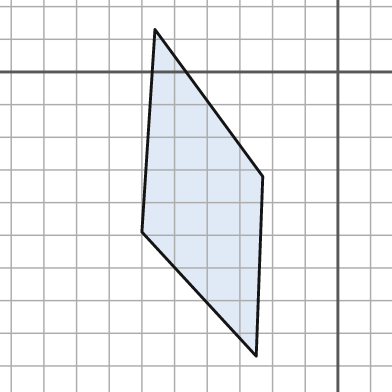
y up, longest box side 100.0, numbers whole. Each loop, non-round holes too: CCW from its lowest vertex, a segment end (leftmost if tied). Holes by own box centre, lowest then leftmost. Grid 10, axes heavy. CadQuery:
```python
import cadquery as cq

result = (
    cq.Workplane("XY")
    .moveTo(-25.0, -87.0)
    .lineTo(-23.0, -32.0)
    .lineTo(-56.0, 13.0)
    .lineTo(-60.0, -49.0)
    .close()
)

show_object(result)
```